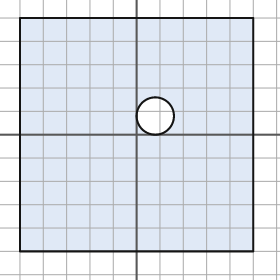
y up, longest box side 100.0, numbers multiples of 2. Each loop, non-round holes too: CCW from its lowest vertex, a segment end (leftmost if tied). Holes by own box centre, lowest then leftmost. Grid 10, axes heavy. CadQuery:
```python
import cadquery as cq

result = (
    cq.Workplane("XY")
    .moveTo(-50.0, -50.0)
    .lineTo(50.0, -50.0)
    .lineTo(50.0, 50.0)
    .lineTo(-50.0, 50.0)
    .close()
    .moveTo(8.0, 8.0)
    .circle(8.0)
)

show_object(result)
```